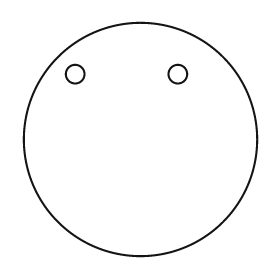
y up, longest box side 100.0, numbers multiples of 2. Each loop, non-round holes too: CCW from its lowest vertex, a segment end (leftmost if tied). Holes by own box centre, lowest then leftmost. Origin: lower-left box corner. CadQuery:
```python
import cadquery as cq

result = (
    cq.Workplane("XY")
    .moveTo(50.0, 50.0)
    .circle(50.0)
    .moveTo(22.0, 78.0)
    .circle(4.0)
    .moveTo(66.0, 78.0)
    .circle(4.0)
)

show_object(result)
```